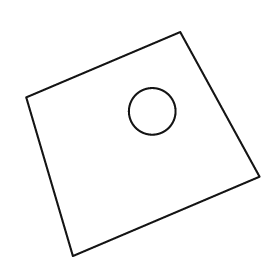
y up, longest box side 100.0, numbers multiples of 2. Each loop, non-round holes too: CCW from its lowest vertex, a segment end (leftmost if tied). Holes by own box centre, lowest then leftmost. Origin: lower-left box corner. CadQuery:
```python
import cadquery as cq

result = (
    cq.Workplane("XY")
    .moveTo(20.0, 0.0)
    .lineTo(100.0, 34.0)
    .lineTo(66.0, 96.0)
    .lineTo(0.0, 68.0)
    .close()
    .moveTo(54.0, 62.0)
    .circle(10.0)
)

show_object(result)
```